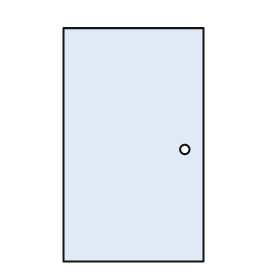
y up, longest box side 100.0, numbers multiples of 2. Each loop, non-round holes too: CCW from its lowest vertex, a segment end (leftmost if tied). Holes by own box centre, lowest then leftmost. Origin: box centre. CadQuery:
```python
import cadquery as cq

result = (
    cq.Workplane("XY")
    .moveTo(-30.0, -50.0)
    .lineTo(30.0, -50.0)
    .lineTo(30.0, 50.0)
    .lineTo(-30.0, 50.0)
    .close()
    .moveTo(22.0, -2.0)
    .circle(2.0)
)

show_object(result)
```